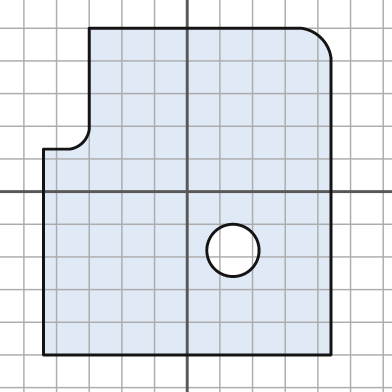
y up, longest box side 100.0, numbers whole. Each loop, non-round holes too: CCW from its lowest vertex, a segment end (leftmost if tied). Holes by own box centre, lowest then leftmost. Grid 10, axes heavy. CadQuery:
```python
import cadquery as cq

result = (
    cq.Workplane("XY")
    .moveTo(-44.0, -50.0)
    .lineTo(44.0, -50.0)
    .lineTo(44.0, 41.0)
    .threePointArc((41.0, 47.0), (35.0, 50.0))
    .lineTo(-30.0, 50.0)
    .lineTo(-30.0, 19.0)
    .threePointArc((-32.0, 15.0), (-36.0, 13.0))
    .lineTo(-44.0, 13.0)
    .close()
    .moveTo(14.0, -18.0)
    .circle(8.0)
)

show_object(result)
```